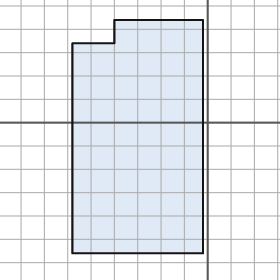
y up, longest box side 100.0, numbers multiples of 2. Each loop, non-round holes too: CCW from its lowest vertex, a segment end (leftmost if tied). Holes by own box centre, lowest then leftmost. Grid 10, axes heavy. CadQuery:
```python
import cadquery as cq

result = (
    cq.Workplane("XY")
    .moveTo(-58.0, -56.0)
    .lineTo(-2.0, -56.0)
    .lineTo(-2.0, 44.0)
    .lineTo(-40.0, 44.0)
    .lineTo(-40.0, 34.0)
    .lineTo(-58.0, 34.0)
    .close()
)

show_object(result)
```